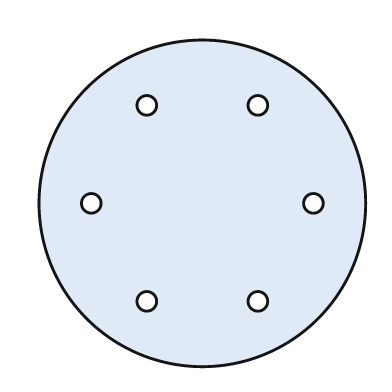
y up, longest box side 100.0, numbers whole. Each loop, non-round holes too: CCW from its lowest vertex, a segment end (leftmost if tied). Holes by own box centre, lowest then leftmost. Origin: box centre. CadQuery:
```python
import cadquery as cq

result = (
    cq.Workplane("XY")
    .moveTo(0.0, 0.0)
    .circle(50.0)
    .moveTo(-17.0, -30.0)
    .circle(3.0)
    .moveTo(17.0, -30.0)
    .circle(3.0)
    .moveTo(-34.0, 0.0)
    .circle(3.0)
    .moveTo(34.0, 0.0)
    .circle(3.0)
    .moveTo(-17.0, 30.0)
    .circle(3.0)
    .moveTo(17.0, 30.0)
    .circle(3.0)
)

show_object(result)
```